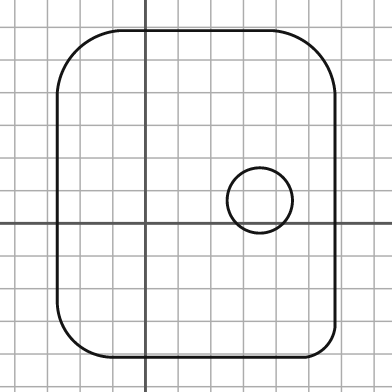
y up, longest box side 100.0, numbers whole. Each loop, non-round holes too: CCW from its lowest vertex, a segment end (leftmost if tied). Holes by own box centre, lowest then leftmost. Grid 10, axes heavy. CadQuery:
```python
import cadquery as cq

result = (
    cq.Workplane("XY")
    .moveTo(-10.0, -41.0)
    .lineTo(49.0, -41.0)
    .threePointArc((55.0, -38.0), (58.0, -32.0))
    .lineTo(58.0, 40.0)
    .threePointArc((52.0, 53.0), (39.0, 59.0))
    .lineTo(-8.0, 59.0)
    .threePointArc((-21.0, 53.0), (-27.0, 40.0))
    .lineTo(-27.0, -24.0)
    .threePointArc((-22.0, -36.0), (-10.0, -41.0))
    .close()
    .moveTo(35.0, 7.0)
    .circle(10.0)
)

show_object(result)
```